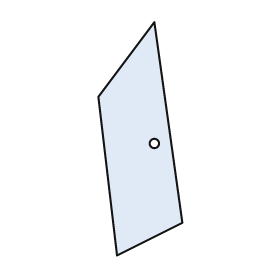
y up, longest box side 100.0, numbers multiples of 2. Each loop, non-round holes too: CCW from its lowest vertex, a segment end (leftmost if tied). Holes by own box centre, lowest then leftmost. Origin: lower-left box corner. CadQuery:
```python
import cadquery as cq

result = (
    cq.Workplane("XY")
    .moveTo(8.0, 0.0)
    .lineTo(36.0, 14.0)
    .lineTo(24.0, 100.0)
    .lineTo(0.0, 68.0)
    .close()
    .moveTo(24.0, 48.0)
    .circle(2.0)
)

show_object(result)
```